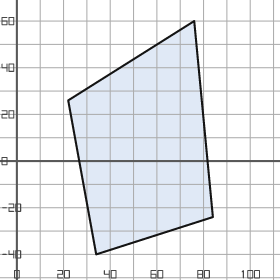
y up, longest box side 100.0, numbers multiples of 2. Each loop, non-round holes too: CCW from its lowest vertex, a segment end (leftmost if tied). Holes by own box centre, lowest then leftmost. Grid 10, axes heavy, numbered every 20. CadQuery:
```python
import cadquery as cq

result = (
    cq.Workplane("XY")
    .moveTo(34.0, -40.0)
    .lineTo(84.0, -24.0)
    .lineTo(76.0, 60.0)
    .lineTo(22.0, 26.0)
    .close()
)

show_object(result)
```